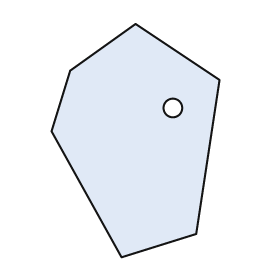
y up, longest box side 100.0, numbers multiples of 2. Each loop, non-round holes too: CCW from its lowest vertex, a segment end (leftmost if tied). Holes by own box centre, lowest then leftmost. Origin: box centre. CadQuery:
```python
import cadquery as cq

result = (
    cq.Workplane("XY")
    .moveTo(-6.0, -50.0)
    .lineTo(26.0, -40.0)
    .lineTo(36.0, 26.0)
    .lineTo(0.0, 50.0)
    .lineTo(-28.0, 30.0)
    .lineTo(-36.0, 4.0)
    .close()
    .moveTo(16.0, 14.0)
    .circle(4.0)
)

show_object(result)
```